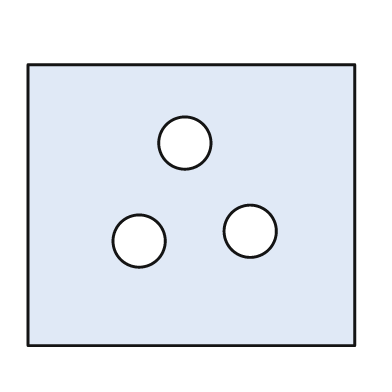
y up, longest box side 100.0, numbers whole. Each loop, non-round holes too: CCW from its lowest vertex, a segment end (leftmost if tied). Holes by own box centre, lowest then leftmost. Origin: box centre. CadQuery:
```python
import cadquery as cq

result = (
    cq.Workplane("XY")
    .moveTo(-50.0, -43.0)
    .lineTo(50.0, -43.0)
    .lineTo(50.0, 43.0)
    .lineTo(-50.0, 43.0)
    .close()
    .moveTo(-16.0, -11.0)
    .circle(8.0)
    .moveTo(18.0, -8.0)
    .circle(8.0)
    .moveTo(-2.0, 19.0)
    .circle(8.0)
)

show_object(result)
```